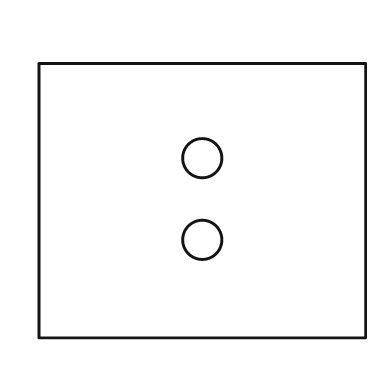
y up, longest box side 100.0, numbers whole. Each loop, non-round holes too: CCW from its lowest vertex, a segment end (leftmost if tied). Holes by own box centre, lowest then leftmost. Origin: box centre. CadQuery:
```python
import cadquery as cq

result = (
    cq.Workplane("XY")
    .moveTo(-50.0, -42.0)
    .lineTo(50.0, -42.0)
    .lineTo(50.0, 42.0)
    .lineTo(-50.0, 42.0)
    .close()
    .moveTo(0.0, -12.0)
    .circle(6.0)
    .moveTo(0.0, 13.0)
    .circle(6.0)
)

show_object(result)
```